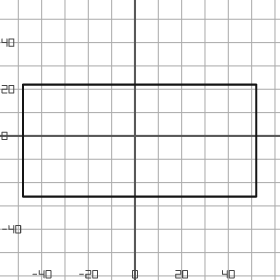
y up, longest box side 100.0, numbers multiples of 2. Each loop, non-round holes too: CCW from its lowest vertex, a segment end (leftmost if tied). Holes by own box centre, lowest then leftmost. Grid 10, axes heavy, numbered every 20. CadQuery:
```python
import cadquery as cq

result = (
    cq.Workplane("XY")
    .moveTo(-48.0, -26.0)
    .lineTo(52.0, -26.0)
    .lineTo(52.0, 22.0)
    .lineTo(-48.0, 22.0)
    .close()
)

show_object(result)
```